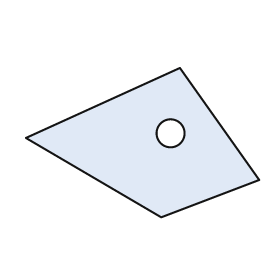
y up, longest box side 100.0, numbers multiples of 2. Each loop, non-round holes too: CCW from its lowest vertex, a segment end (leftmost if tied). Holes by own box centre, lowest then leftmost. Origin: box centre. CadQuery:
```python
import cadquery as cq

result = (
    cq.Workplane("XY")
    .moveTo(8.0, -32.0)
    .lineTo(50.0, -16.0)
    .lineTo(16.0, 32.0)
    .lineTo(-50.0, 2.0)
    .close()
    .moveTo(12.0, 4.0)
    .circle(6.0)
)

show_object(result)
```